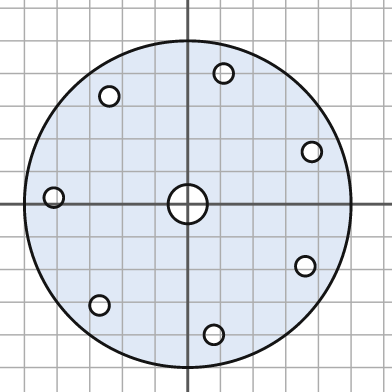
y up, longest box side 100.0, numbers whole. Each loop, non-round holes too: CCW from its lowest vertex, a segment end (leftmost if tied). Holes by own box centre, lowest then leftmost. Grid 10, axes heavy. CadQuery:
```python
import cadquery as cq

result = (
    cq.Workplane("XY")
    .moveTo(0.0, 0.0)
    .circle(50.0)
    .moveTo(8.0, -40.0)
    .circle(3.0)
    .moveTo(-27.0, -31.0)
    .circle(3.0)
    .moveTo(36.0, -19.0)
    .circle(3.0)
    .moveTo(0.0, 0.0)
    .circle(6.0)
    .moveTo(-41.0, 2.0)
    .circle(3.0)
    .moveTo(38.0, 16.0)
    .circle(3.0)
    .moveTo(-24.0, 33.0)
    .circle(3.0)
    .moveTo(11.0, 40.0)
    .circle(3.0)
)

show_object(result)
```